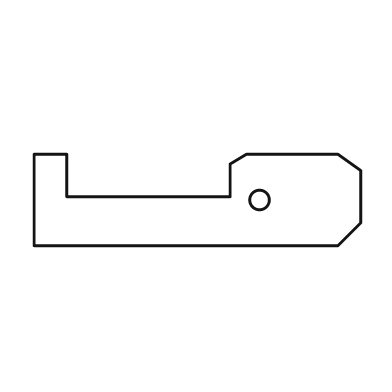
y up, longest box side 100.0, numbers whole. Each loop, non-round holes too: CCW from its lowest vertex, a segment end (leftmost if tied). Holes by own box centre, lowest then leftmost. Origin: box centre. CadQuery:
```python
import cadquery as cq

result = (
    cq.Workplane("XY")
    .moveTo(-50.0, -14.0)
    .lineTo(43.0, -14.0)
    .lineTo(50.0, -7.0)
    .lineTo(50.0, 9.0)
    .lineTo(43.0, 14.0)
    .lineTo(15.0, 14.0)
    .lineTo(10.0, 11.0)
    .lineTo(10.0, 1.0)
    .lineTo(-40.0, 1.0)
    .lineTo(-40.0, 14.0)
    .lineTo(-50.0, 14.0)
    .close()
    .moveTo(19.0, 0.0)
    .circle(3.0)
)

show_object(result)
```